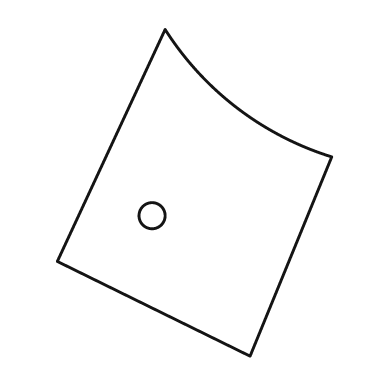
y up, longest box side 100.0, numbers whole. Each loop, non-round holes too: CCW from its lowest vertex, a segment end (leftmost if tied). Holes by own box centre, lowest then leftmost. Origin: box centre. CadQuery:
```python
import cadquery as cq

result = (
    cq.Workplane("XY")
    .moveTo(17.0, -50.0)
    .lineTo(42.0, 11.0)
    .threePointArc((13.0, 26.0), (-9.0, 50.0))
    .lineTo(-42.0, -21.0)
    .close()
    .moveTo(-13.0, -7.0)
    .circle(4.0)
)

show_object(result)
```